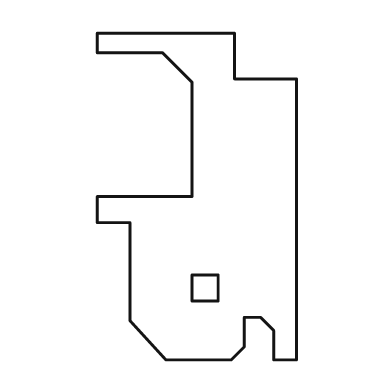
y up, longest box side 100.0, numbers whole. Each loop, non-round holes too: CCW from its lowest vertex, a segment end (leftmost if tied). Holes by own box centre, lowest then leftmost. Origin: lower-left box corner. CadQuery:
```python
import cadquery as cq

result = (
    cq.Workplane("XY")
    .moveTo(21.0, 0.0)
    .lineTo(41.0, 0.0)
    .lineTo(45.0, 4.0)
    .lineTo(45.0, 13.0)
    .lineTo(50.0, 13.0)
    .lineTo(54.0, 9.0)
    .lineTo(54.0, 0.0)
    .lineTo(61.0, 0.0)
    .lineTo(61.0, 86.0)
    .lineTo(42.0, 86.0)
    .lineTo(42.0, 100.0)
    .lineTo(0.0, 100.0)
    .lineTo(0.0, 94.0)
    .lineTo(20.0, 94.0)
    .lineTo(29.0, 85.0)
    .lineTo(29.0, 50.0)
    .lineTo(0.0, 50.0)
    .lineTo(0.0, 42.0)
    .lineTo(10.0, 42.0)
    .lineTo(10.0, 12.0)
    .close()
    .moveTo(29.0, 18.0)
    .lineTo(37.0, 18.0)
    .lineTo(37.0, 26.0)
    .lineTo(29.0, 26.0)
    .close()
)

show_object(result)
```